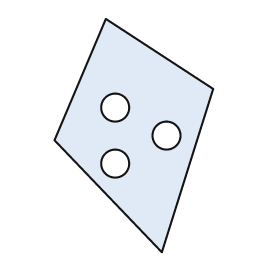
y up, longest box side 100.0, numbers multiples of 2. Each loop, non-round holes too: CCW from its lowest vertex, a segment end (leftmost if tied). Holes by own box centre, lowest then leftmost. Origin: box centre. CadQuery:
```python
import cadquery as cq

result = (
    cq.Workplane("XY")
    .moveTo(12.0, -50.0)
    .lineTo(34.0, 20.0)
    .lineTo(-12.0, 50.0)
    .lineTo(-34.0, -2.0)
    .close()
    .moveTo(-8.0, -12.0)
    .circle(6.0)
    .moveTo(14.0, 0.0)
    .circle(6.0)
    .moveTo(-8.0, 12.0)
    .circle(6.0)
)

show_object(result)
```